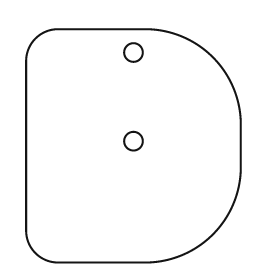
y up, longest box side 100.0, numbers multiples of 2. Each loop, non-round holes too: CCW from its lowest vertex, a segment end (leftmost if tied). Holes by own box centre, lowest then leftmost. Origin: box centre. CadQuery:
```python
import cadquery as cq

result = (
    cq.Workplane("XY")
    .moveTo(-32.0, -50.0)
    .lineTo(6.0, -50.0)
    .threePointArc((34.0, -38.0), (46.0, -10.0))
    .lineTo(46.0, 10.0)
    .threePointArc((34.0, 38.0), (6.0, 50.0))
    .lineTo(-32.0, 50.0)
    .threePointArc((-42.0, 46.0), (-46.0, 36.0))
    .lineTo(-46.0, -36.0)
    .threePointArc((-42.0, -46.0), (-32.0, -50.0))
    .close()
    .moveTo(0.0, 2.0)
    .circle(4.0)
    .moveTo(0.0, 40.0)
    .circle(4.0)
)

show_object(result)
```